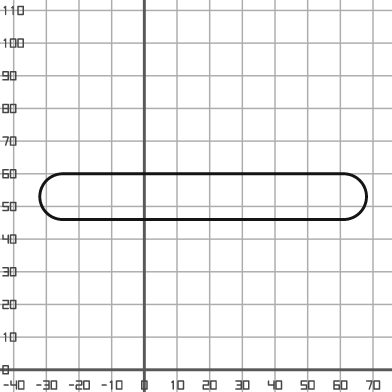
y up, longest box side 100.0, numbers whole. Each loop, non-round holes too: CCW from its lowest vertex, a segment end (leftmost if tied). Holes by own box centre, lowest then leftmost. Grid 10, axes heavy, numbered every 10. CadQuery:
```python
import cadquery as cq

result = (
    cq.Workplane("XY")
    .moveTo(-25.0, 46.0)
    .lineTo(61.0, 46.0)
    .threePointArc((68.0, 53.0), (61.0, 60.0))
    .lineTo(-25.0, 60.0)
    .threePointArc((-32.0, 53.0), (-25.0, 46.0))
    .close()
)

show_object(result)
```